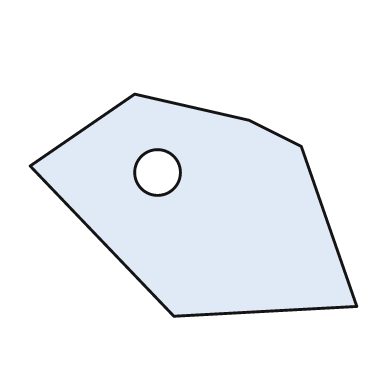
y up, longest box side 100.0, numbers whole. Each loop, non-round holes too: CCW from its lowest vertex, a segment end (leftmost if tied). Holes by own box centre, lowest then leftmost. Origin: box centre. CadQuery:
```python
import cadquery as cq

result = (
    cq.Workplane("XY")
    .moveTo(-6.0, -34.0)
    .lineTo(50.0, -31.0)
    .lineTo(33.0, 18.0)
    .lineTo(17.0, 26.0)
    .lineTo(-18.0, 34.0)
    .lineTo(-50.0, 12.0)
    .close()
    .moveTo(-11.0, 10.0)
    .circle(7.0)
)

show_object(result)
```